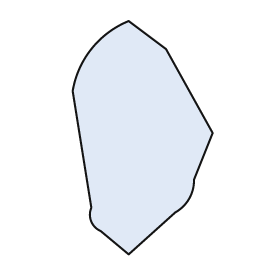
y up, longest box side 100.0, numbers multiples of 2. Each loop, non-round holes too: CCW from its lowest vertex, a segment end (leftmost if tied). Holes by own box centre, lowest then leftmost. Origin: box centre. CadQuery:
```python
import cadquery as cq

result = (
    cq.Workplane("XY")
    .moveTo(-6.0, -50.0)
    .lineTo(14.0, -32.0)
    .threePointArc((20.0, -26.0), (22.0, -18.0))
    .lineTo(30.0, 2.0)
    .lineTo(10.0, 38.0)
    .lineTo(-6.0, 50.0)
    .threePointArc((-22.0, 38.0), (-30.0, 20.0))
    .lineTo(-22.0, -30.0)
    .threePointArc((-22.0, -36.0), (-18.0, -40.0))
    .close()
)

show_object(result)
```